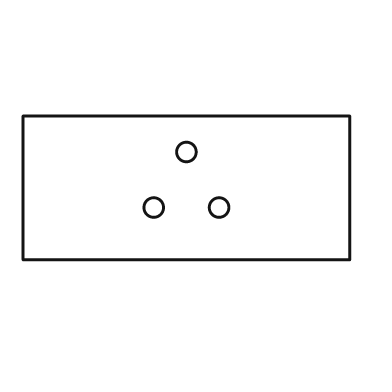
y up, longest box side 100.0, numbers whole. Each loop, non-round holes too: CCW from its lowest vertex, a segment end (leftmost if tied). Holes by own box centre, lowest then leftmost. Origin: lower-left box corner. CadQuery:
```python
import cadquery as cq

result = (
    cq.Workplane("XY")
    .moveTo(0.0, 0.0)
    .lineTo(100.0, 0.0)
    .lineTo(100.0, 44.0)
    .lineTo(0.0, 44.0)
    .close()
    .moveTo(40.0, 16.0)
    .circle(3.0)
    .moveTo(60.0, 16.0)
    .circle(3.0)
    .moveTo(50.0, 33.0)
    .circle(3.0)
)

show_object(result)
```